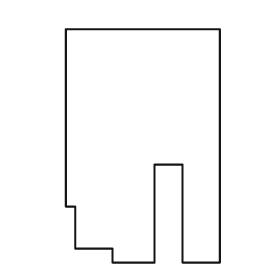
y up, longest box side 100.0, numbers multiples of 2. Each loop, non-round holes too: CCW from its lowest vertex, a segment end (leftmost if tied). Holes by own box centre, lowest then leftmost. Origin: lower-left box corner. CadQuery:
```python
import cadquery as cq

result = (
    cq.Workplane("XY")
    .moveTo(20.0, 0.0)
    .lineTo(38.0, 0.0)
    .lineTo(38.0, 42.0)
    .lineTo(50.0, 42.0)
    .lineTo(50.0, 0.0)
    .lineTo(66.0, 0.0)
    .lineTo(66.0, 100.0)
    .lineTo(0.0, 100.0)
    .lineTo(0.0, 24.0)
    .lineTo(4.0, 24.0)
    .lineTo(4.0, 6.0)
    .lineTo(20.0, 6.0)
    .close()
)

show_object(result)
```